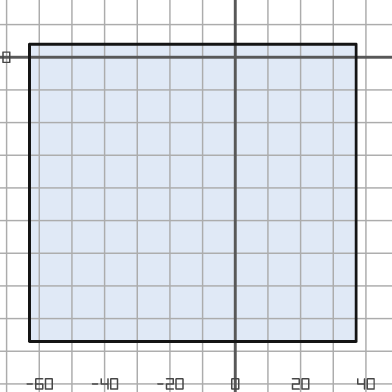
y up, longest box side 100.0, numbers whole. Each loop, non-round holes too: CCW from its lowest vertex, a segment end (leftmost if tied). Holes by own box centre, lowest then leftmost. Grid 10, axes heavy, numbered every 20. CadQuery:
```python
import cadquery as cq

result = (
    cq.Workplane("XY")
    .moveTo(-63.0, -87.0)
    .lineTo(37.0, -87.0)
    .lineTo(37.0, 4.0)
    .lineTo(-63.0, 4.0)
    .close()
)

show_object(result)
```